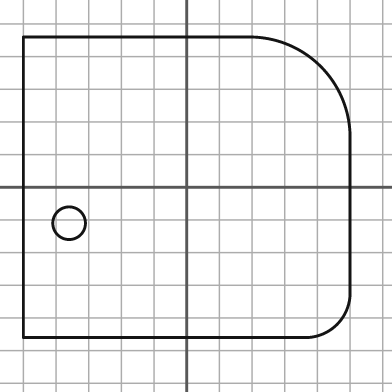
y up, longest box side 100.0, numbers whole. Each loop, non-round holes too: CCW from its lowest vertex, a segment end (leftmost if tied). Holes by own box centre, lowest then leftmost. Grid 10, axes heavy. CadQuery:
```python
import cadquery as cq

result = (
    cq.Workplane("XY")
    .moveTo(-50.0, -46.0)
    .lineTo(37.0, -46.0)
    .threePointArc((46.0, -42.0), (50.0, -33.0))
    .lineTo(50.0, 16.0)
    .threePointArc((41.0, 37.0), (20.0, 46.0))
    .lineTo(-50.0, 46.0)
    .close()
    .moveTo(-36.0, -11.0)
    .circle(5.0)
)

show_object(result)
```